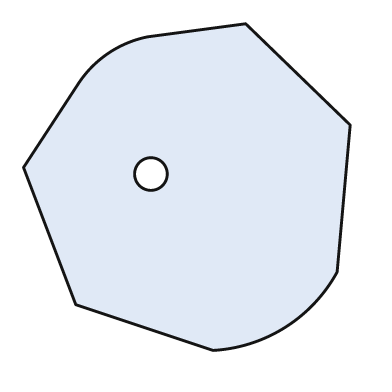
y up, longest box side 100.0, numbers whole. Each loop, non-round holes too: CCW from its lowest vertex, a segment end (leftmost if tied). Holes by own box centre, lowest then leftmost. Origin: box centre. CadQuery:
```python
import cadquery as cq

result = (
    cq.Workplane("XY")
    .moveTo(8.0, -50.0)
    .threePointArc((30.0, -43.0), (46.0, -26.0))
    .lineTo(50.0, 19.0)
    .lineTo(18.0, 50.0)
    .lineTo(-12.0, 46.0)
    .threePointArc((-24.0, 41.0), (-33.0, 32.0))
    .lineTo(-50.0, 6.0)
    .lineTo(-34.0, -36.0)
    .close()
    .moveTo(-11.0, 4.0)
    .circle(5.0)
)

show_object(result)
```